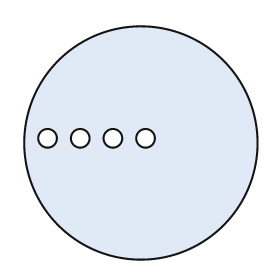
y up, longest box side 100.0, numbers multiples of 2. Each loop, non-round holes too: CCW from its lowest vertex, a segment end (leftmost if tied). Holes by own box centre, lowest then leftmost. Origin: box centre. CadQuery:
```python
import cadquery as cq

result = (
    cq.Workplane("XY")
    .moveTo(0.0, 0.0)
    .circle(50.0)
    .moveTo(-40.0, 2.0)
    .circle(4.0)
    .moveTo(-26.0, 2.0)
    .circle(4.0)
    .moveTo(-12.0, 2.0)
    .circle(4.0)
    .moveTo(2.0, 2.0)
    .circle(4.0)
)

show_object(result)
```